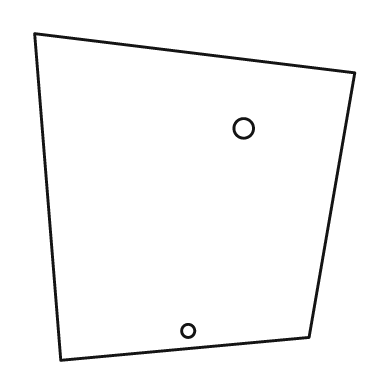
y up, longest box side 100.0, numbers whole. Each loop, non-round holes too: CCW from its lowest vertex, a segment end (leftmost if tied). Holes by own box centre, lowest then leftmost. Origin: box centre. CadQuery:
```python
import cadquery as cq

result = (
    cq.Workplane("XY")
    .moveTo(-41.0, -50.0)
    .lineTo(35.0, -43.0)
    .lineTo(49.0, 38.0)
    .lineTo(-49.0, 50.0)
    .close()
    .moveTo(-2.0, -41.0)
    .circle(2.0)
    .moveTo(15.0, 21.0)
    .circle(3.0)
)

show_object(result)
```